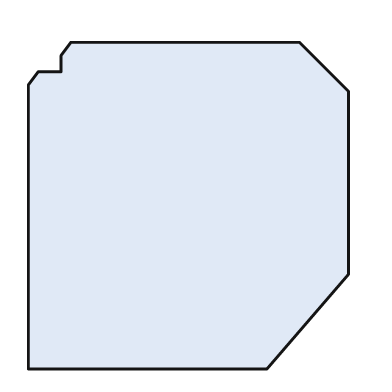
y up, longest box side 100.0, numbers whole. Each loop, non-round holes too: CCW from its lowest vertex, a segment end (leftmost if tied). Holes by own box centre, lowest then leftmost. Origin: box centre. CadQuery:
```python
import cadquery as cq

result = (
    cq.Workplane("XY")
    .moveTo(-49.0, -50.0)
    .lineTo(24.0, -50.0)
    .lineTo(49.0, -21.0)
    .lineTo(49.0, 35.0)
    .lineTo(34.0, 50.0)
    .lineTo(-36.0, 50.0)
    .lineTo(-39.0, 46.0)
    .lineTo(-39.0, 41.0)
    .lineTo(-46.0, 41.0)
    .lineTo(-49.0, 37.0)
    .close()
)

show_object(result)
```